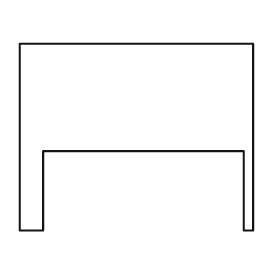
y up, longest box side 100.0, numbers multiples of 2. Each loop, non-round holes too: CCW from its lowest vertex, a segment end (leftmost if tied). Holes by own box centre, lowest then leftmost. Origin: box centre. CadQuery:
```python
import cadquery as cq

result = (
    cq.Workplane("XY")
    .moveTo(-50.0, -40.0)
    .lineTo(-40.0, -40.0)
    .lineTo(-40.0, -6.0)
    .lineTo(46.0, -6.0)
    .lineTo(46.0, -40.0)
    .lineTo(50.0, -40.0)
    .lineTo(50.0, 40.0)
    .lineTo(-50.0, 40.0)
    .close()
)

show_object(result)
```